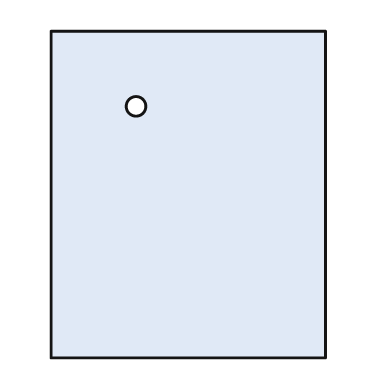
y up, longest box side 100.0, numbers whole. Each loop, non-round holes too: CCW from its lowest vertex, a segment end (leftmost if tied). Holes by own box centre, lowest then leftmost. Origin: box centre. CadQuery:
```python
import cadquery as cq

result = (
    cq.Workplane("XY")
    .moveTo(-42.0, -50.0)
    .lineTo(42.0, -50.0)
    .lineTo(42.0, 50.0)
    .lineTo(-42.0, 50.0)
    .close()
    .moveTo(-16.0, 27.0)
    .circle(3.0)
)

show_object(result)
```